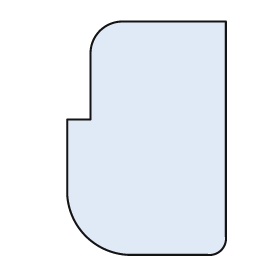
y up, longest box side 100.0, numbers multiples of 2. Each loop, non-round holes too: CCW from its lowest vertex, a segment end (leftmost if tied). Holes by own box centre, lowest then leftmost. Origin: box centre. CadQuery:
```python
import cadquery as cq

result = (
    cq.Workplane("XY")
    .moveTo(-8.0, -50.0)
    .lineTo(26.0, -50.0)
    .threePointArc((32.0, -48.0), (34.0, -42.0))
    .lineTo(34.0, 50.0)
    .lineTo(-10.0, 50.0)
    .threePointArc((-20.0, 46.0), (-24.0, 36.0))
    .lineTo(-24.0, 8.0)
    .lineTo(-34.0, 8.0)
    .lineTo(-34.0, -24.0)
    .threePointArc((-26.0, -42.0), (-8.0, -50.0))
    .close()
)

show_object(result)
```